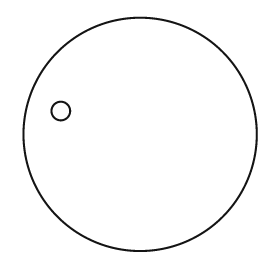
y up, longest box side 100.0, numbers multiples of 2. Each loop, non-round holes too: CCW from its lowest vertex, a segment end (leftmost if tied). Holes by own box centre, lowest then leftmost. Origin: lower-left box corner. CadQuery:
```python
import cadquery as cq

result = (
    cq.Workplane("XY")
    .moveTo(50.0, 50.0)
    .circle(50.0)
    .moveTo(16.0, 60.0)
    .circle(4.0)
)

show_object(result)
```